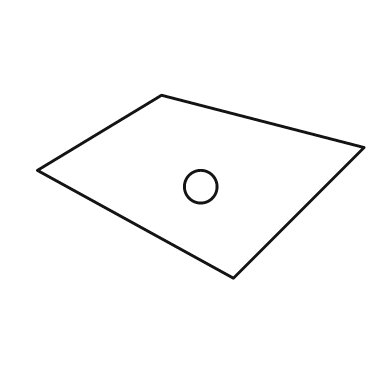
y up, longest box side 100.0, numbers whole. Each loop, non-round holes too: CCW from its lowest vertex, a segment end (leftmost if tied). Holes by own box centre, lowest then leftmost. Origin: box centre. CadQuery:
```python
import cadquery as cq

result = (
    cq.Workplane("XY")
    .moveTo(10.0, -28.0)
    .lineTo(50.0, 12.0)
    .lineTo(-12.0, 28.0)
    .lineTo(-50.0, 5.0)
    .close()
    .moveTo(0.0, 0.0)
    .circle(5.0)
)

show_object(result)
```